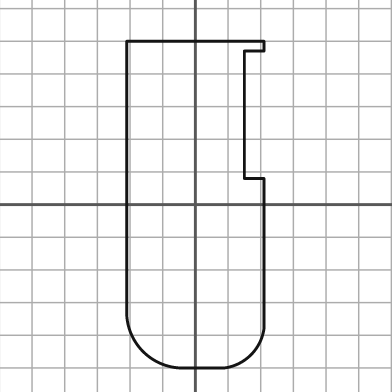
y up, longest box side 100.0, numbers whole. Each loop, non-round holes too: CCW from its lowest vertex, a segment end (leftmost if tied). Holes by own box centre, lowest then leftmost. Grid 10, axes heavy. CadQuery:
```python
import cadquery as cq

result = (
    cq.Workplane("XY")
    .moveTo(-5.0, -50.0)
    .lineTo(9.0, -50.0)
    .threePointArc((17.0, -46.0), (21.0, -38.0))
    .lineTo(21.0, 8.0)
    .lineTo(15.0, 8.0)
    .lineTo(15.0, 47.0)
    .lineTo(21.0, 47.0)
    .lineTo(21.0, 50.0)
    .lineTo(-21.0, 50.0)
    .lineTo(-21.0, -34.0)
    .threePointArc((-16.0, -45.0), (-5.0, -50.0))
    .close()
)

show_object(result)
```